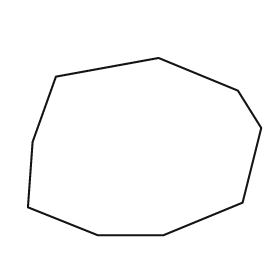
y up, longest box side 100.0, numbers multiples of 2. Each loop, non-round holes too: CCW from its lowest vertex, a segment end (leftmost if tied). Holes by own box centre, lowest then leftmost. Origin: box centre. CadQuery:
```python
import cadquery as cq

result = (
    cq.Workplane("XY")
    .moveTo(-20.0, -38.0)
    .lineTo(8.0, -38.0)
    .lineTo(42.0, -24.0)
    .lineTo(50.0, 8.0)
    .lineTo(40.0, 24.0)
    .lineTo(6.0, 38.0)
    .lineTo(-38.0, 30.0)
    .lineTo(-48.0, 2.0)
    .lineTo(-50.0, -26.0)
    .close()
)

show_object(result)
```